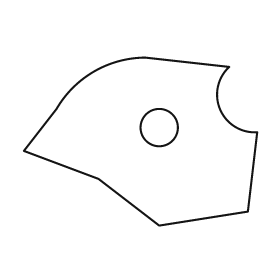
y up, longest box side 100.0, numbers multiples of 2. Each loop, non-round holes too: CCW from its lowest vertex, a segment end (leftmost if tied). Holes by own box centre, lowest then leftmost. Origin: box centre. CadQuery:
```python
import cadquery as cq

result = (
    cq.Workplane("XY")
    .moveTo(8.0, -36.0)
    .lineTo(46.0, -30.0)
    .lineTo(50.0, 4.0)
    .threePointArc((34.0, 14.0), (38.0, 32.0))
    .lineTo(2.0, 36.0)
    .threePointArc((-20.0, 30.0), (-36.0, 14.0))
    .lineTo(-50.0, -4.0)
    .lineTo(-18.0, -16.0)
    .close()
    .moveTo(8.0, 6.0)
    .circle(8.0)
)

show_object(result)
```